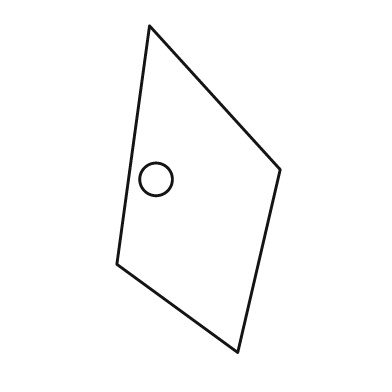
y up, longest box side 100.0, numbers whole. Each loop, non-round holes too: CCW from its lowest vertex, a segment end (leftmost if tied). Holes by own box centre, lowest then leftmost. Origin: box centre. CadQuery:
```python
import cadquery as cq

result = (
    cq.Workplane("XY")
    .moveTo(12.0, -50.0)
    .lineTo(25.0, 6.0)
    .lineTo(-15.0, 50.0)
    .lineTo(-25.0, -23.0)
    .close()
    .moveTo(-13.0, 3.0)
    .circle(5.0)
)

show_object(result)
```